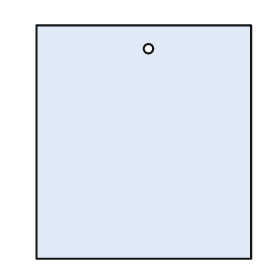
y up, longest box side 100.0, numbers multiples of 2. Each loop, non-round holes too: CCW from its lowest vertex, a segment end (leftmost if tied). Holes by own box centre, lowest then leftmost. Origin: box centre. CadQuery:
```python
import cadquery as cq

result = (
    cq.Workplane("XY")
    .moveTo(-46.0, -50.0)
    .lineTo(46.0, -50.0)
    .lineTo(46.0, 50.0)
    .lineTo(-46.0, 50.0)
    .close()
    .moveTo(2.0, 40.0)
    .circle(2.0)
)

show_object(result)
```